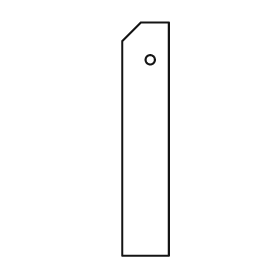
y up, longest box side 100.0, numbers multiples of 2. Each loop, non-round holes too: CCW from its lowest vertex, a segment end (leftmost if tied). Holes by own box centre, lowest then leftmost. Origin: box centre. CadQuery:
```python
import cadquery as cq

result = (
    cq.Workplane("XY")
    .moveTo(-10.0, -50.0)
    .lineTo(10.0, -50.0)
    .lineTo(10.0, 50.0)
    .lineTo(-2.0, 50.0)
    .lineTo(-10.0, 42.0)
    .close()
    .moveTo(2.0, 34.0)
    .circle(2.0)
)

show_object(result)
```